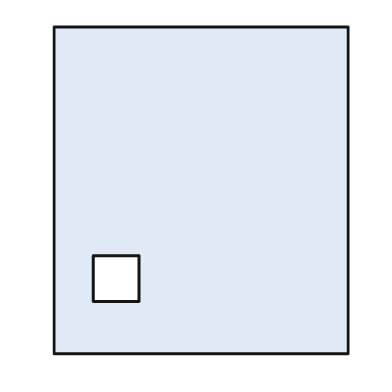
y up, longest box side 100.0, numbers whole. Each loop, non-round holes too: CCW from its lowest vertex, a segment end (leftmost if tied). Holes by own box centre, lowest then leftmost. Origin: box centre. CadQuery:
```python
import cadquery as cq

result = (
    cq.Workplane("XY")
    .moveTo(-45.0, -50.0)
    .lineTo(45.0, -50.0)
    .lineTo(45.0, 50.0)
    .lineTo(-45.0, 50.0)
    .close()
    .moveTo(-33.0, -34.0)
    .lineTo(-19.0, -34.0)
    .lineTo(-19.0, -20.0)
    .lineTo(-33.0, -20.0)
    .close()
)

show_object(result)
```